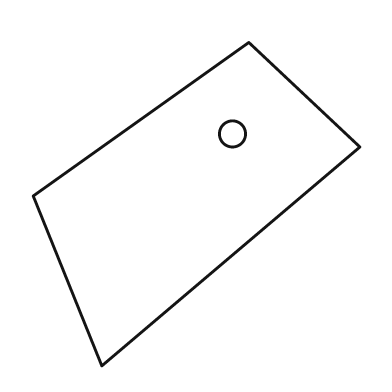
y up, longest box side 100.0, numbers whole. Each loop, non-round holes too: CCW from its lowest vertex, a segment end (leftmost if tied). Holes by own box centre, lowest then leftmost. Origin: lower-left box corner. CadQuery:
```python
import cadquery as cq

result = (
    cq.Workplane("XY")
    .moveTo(21.0, 0.0)
    .lineTo(100.0, 67.0)
    .lineTo(66.0, 99.0)
    .lineTo(0.0, 52.0)
    .close()
    .moveTo(61.0, 71.0)
    .circle(4.0)
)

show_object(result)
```